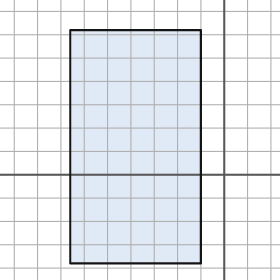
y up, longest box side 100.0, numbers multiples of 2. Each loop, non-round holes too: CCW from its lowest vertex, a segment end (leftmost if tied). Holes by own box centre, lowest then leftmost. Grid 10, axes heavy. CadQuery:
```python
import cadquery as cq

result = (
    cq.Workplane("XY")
    .moveTo(-66.0, -38.0)
    .lineTo(-10.0, -38.0)
    .lineTo(-10.0, 62.0)
    .lineTo(-66.0, 62.0)
    .close()
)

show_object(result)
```